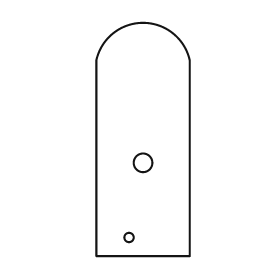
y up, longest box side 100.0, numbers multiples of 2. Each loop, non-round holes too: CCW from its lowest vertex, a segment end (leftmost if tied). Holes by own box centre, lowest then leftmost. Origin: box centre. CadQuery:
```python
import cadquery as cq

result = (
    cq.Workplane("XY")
    .moveTo(-20.0, -50.0)
    .lineTo(20.0, -50.0)
    .lineTo(20.0, 34.0)
    .threePointArc((0.0, 50.0), (-20.0, 34.0))
    .close()
    .moveTo(-6.0, -42.0)
    .circle(2.0)
    .moveTo(0.0, -10.0)
    .circle(4.0)
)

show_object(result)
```